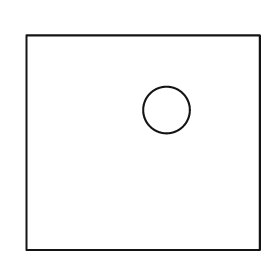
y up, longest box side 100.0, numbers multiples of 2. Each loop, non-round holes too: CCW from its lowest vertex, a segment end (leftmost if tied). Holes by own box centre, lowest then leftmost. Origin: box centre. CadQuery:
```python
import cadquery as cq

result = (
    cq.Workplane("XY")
    .moveTo(-50.0, -46.0)
    .lineTo(50.0, -46.0)
    .lineTo(50.0, 46.0)
    .lineTo(-50.0, 46.0)
    .close()
    .moveTo(10.0, 14.0)
    .circle(10.0)
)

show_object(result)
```